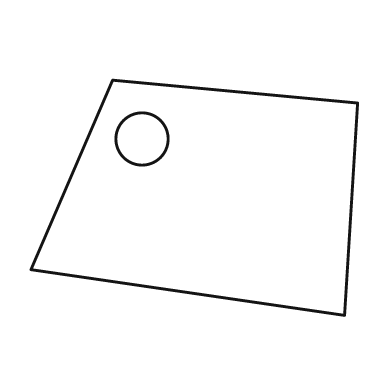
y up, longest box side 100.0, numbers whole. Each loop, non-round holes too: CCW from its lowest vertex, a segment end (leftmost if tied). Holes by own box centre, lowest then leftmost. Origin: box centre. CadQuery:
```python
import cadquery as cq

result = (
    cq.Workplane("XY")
    .moveTo(46.0, -36.0)
    .lineTo(50.0, 29.0)
    .lineTo(-25.0, 36.0)
    .lineTo(-50.0, -22.0)
    .close()
    .moveTo(-16.0, 18.0)
    .circle(8.0)
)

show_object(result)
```